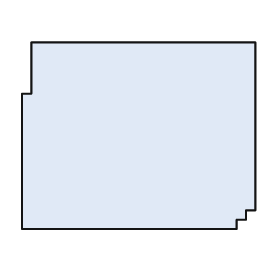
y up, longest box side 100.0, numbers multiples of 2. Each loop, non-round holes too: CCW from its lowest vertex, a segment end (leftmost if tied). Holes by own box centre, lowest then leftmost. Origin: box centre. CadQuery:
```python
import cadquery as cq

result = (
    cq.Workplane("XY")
    .moveTo(-50.0, -40.0)
    .lineTo(42.0, -40.0)
    .lineTo(42.0, -36.0)
    .lineTo(46.0, -36.0)
    .lineTo(46.0, -32.0)
    .lineTo(50.0, -32.0)
    .lineTo(50.0, 40.0)
    .lineTo(-46.0, 40.0)
    .lineTo(-46.0, 18.0)
    .lineTo(-50.0, 18.0)
    .close()
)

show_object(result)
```